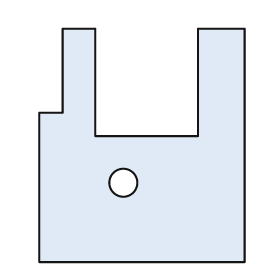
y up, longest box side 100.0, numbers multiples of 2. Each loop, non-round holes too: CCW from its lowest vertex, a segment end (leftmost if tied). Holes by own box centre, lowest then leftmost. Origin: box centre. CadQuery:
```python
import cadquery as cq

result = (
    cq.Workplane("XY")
    .moveTo(-44.0, -50.0)
    .lineTo(44.0, -50.0)
    .lineTo(44.0, 50.0)
    .lineTo(24.0, 50.0)
    .lineTo(24.0, 4.0)
    .lineTo(-20.0, 4.0)
    .lineTo(-20.0, 50.0)
    .lineTo(-34.0, 50.0)
    .lineTo(-34.0, 14.0)
    .lineTo(-44.0, 14.0)
    .close()
    .moveTo(-8.0, -16.0)
    .circle(6.0)
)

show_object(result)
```